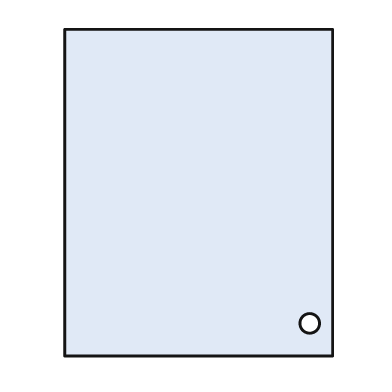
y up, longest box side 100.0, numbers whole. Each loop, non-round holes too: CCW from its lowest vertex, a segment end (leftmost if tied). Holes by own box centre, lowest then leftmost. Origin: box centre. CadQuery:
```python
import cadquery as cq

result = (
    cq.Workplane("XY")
    .moveTo(-41.0, -50.0)
    .lineTo(41.0, -50.0)
    .lineTo(41.0, 50.0)
    .lineTo(-41.0, 50.0)
    .close()
    .moveTo(34.0, -40.0)
    .circle(3.0)
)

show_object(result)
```